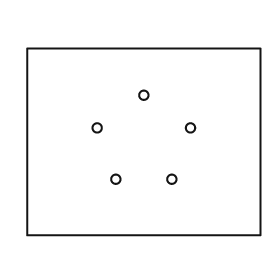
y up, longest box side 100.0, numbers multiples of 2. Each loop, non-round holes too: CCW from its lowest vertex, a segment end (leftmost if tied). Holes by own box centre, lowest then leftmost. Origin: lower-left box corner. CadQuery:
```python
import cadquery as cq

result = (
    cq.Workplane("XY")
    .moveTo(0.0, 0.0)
    .lineTo(100.0, 0.0)
    .lineTo(100.0, 80.0)
    .lineTo(0.0, 80.0)
    .close()
    .moveTo(38.0, 24.0)
    .circle(2.0)
    .moveTo(62.0, 24.0)
    .circle(2.0)
    .moveTo(30.0, 46.0)
    .circle(2.0)
    .moveTo(70.0, 46.0)
    .circle(2.0)
    .moveTo(50.0, 60.0)
    .circle(2.0)
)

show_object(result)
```